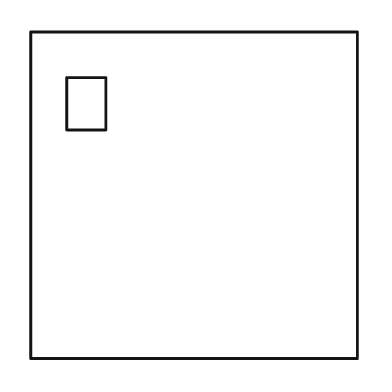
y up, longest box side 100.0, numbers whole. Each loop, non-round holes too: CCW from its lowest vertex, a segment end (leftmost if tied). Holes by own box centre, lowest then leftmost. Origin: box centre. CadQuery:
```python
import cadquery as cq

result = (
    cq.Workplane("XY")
    .moveTo(-50.0, -50.0)
    .lineTo(50.0, -50.0)
    .lineTo(50.0, 50.0)
    .lineTo(-50.0, 50.0)
    .close()
    .moveTo(-39.0, 20.0)
    .lineTo(-27.0, 20.0)
    .lineTo(-27.0, 36.0)
    .lineTo(-39.0, 36.0)
    .close()
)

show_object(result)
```